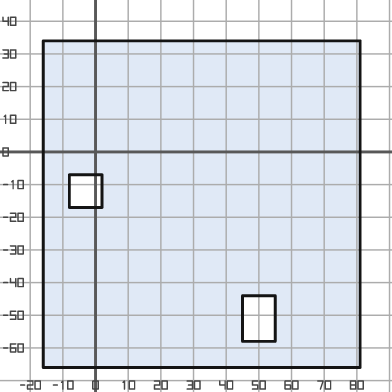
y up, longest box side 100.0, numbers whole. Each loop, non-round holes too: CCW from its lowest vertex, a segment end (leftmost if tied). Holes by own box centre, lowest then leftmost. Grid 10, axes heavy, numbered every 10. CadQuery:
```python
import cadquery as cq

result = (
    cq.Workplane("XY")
    .moveTo(-16.0, -66.0)
    .lineTo(81.0, -66.0)
    .lineTo(81.0, 34.0)
    .lineTo(-16.0, 34.0)
    .close()
    .moveTo(45.0, -58.0)
    .lineTo(55.0, -58.0)
    .lineTo(55.0, -44.0)
    .lineTo(45.0, -44.0)
    .close()
    .moveTo(-8.0, -17.0)
    .lineTo(2.0, -17.0)
    .lineTo(2.0, -7.0)
    .lineTo(-8.0, -7.0)
    .close()
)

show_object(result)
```